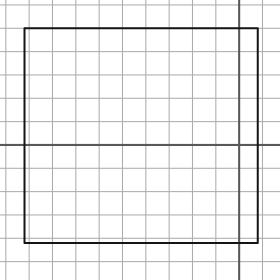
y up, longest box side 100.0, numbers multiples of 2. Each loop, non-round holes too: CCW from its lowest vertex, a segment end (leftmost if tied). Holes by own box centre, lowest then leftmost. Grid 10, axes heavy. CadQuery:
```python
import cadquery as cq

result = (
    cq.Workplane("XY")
    .moveTo(-92.0, -42.0)
    .lineTo(8.0, -42.0)
    .lineTo(8.0, 50.0)
    .lineTo(-92.0, 50.0)
    .close()
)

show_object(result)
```